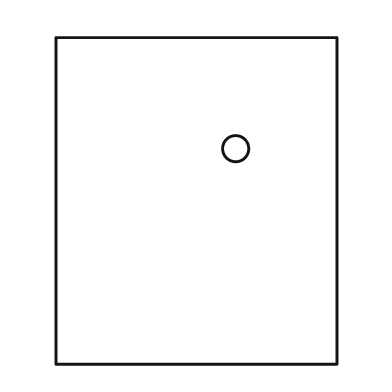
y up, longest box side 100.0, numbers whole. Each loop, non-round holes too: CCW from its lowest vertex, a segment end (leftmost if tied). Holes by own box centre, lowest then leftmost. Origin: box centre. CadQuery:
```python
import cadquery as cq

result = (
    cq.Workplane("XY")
    .moveTo(-43.0, -50.0)
    .lineTo(43.0, -50.0)
    .lineTo(43.0, 50.0)
    .lineTo(-43.0, 50.0)
    .close()
    .moveTo(12.0, 16.0)
    .circle(4.0)
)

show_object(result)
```